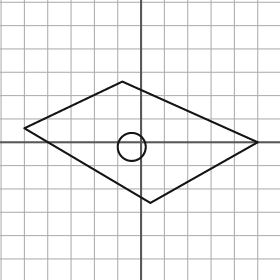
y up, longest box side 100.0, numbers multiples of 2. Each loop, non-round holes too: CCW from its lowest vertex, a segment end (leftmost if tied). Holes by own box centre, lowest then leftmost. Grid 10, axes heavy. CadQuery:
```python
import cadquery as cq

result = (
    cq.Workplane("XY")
    .moveTo(4.0, -26.0)
    .lineTo(50.0, 0.0)
    .lineTo(-8.0, 26.0)
    .lineTo(-50.0, 6.0)
    .close()
    .moveTo(-4.0, -2.0)
    .circle(6.0)
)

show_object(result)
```